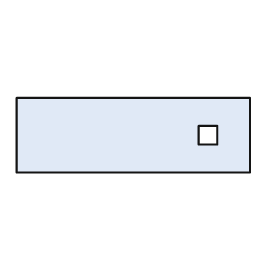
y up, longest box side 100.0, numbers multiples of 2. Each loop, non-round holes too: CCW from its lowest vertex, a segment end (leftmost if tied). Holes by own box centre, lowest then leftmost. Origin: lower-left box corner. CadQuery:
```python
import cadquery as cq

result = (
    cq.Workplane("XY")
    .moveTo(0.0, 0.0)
    .lineTo(100.0, 0.0)
    .lineTo(100.0, 32.0)
    .lineTo(0.0, 32.0)
    .close()
    .moveTo(78.0, 12.0)
    .lineTo(86.0, 12.0)
    .lineTo(86.0, 20.0)
    .lineTo(78.0, 20.0)
    .close()
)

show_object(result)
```